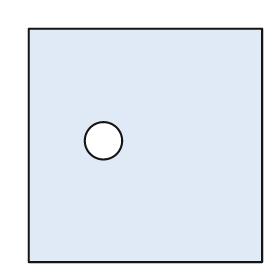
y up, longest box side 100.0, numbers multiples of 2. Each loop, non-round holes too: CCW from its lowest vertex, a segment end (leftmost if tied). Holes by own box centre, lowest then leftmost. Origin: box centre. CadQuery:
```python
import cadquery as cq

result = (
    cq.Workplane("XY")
    .moveTo(-50.0, -50.0)
    .lineTo(50.0, -50.0)
    .lineTo(50.0, 50.0)
    .lineTo(-50.0, 50.0)
    .close()
    .moveTo(-18.0, 2.0)
    .circle(8.0)
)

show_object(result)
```